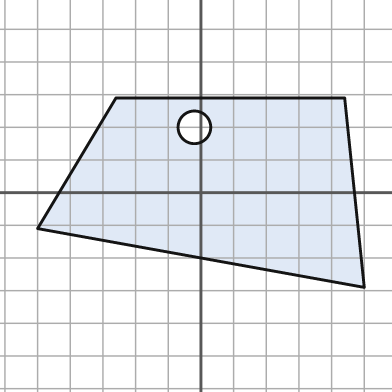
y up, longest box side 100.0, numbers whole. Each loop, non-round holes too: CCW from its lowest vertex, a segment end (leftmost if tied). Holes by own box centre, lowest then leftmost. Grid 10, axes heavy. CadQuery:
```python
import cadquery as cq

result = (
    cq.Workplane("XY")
    .moveTo(50.0, -29.0)
    .lineTo(44.0, 29.0)
    .lineTo(-26.0, 29.0)
    .lineTo(-50.0, -11.0)
    .close()
    .moveTo(-2.0, 20.0)
    .circle(5.0)
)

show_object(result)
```